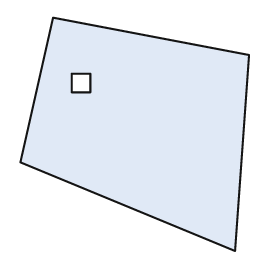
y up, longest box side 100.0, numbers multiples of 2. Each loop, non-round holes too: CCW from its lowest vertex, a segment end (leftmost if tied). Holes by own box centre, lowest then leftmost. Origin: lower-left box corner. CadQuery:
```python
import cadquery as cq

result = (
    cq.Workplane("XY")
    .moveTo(92.0, 0.0)
    .lineTo(98.0, 84.0)
    .lineTo(14.0, 100.0)
    .lineTo(0.0, 38.0)
    .close()
    .moveTo(22.0, 68.0)
    .lineTo(30.0, 68.0)
    .lineTo(30.0, 76.0)
    .lineTo(22.0, 76.0)
    .close()
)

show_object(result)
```